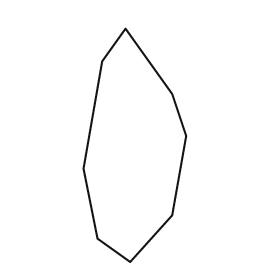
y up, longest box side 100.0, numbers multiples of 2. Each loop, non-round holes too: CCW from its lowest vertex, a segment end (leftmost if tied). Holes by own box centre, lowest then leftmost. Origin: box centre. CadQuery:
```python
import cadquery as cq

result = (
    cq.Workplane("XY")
    .moveTo(-2.0, -50.0)
    .lineTo(16.0, -30.0)
    .lineTo(22.0, 4.0)
    .lineTo(16.0, 22.0)
    .lineTo(-4.0, 50.0)
    .lineTo(-14.0, 36.0)
    .lineTo(-22.0, -10.0)
    .lineTo(-16.0, -40.0)
    .close()
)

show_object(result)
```